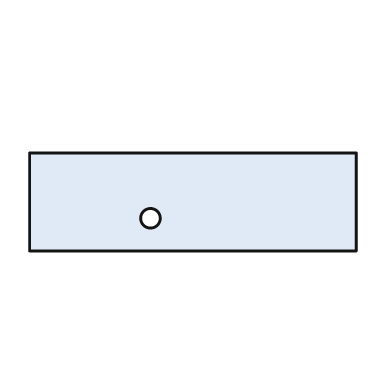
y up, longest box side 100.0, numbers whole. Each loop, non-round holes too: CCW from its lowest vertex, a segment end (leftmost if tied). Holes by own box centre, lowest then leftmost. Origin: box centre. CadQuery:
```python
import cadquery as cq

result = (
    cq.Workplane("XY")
    .moveTo(-50.0, -15.0)
    .lineTo(50.0, -15.0)
    .lineTo(50.0, 15.0)
    .lineTo(-50.0, 15.0)
    .close()
    .moveTo(-13.0, -5.0)
    .circle(3.0)
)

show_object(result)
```